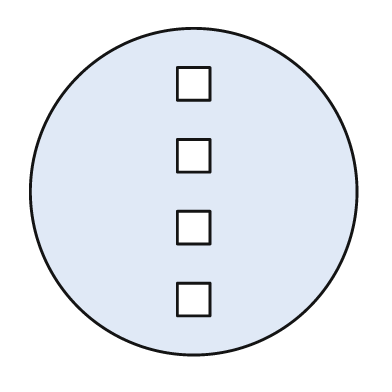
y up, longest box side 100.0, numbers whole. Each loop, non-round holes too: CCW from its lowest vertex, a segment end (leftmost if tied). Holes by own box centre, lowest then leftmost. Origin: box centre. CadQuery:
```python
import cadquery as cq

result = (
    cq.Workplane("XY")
    .moveTo(0.0, 0.0)
    .circle(50.0)
    .moveTo(-5.0, -38.0)
    .lineTo(5.0, -38.0)
    .lineTo(5.0, -28.0)
    .lineTo(-5.0, -28.0)
    .close()
    .moveTo(-5.0, -16.0)
    .lineTo(5.0, -16.0)
    .lineTo(5.0, -6.0)
    .lineTo(-5.0, -6.0)
    .close()
    .moveTo(-5.0, 6.0)
    .lineTo(5.0, 6.0)
    .lineTo(5.0, 16.0)
    .lineTo(-5.0, 16.0)
    .close()
    .moveTo(-5.0, 28.0)
    .lineTo(5.0, 28.0)
    .lineTo(5.0, 38.0)
    .lineTo(-5.0, 38.0)
    .close()
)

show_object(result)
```